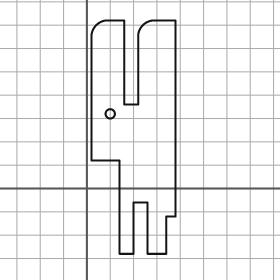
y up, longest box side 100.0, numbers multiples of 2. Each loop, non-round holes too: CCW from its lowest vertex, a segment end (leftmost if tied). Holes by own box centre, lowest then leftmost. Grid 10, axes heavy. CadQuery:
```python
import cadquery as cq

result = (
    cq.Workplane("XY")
    .moveTo(14.0, -28.0)
    .lineTo(20.0, -28.0)
    .lineTo(20.0, -6.0)
    .lineTo(26.0, -6.0)
    .lineTo(26.0, -28.0)
    .lineTo(34.0, -28.0)
    .lineTo(34.0, -12.0)
    .lineTo(38.0, -12.0)
    .lineTo(38.0, 72.0)
    .lineTo(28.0, 72.0)
    .threePointArc((24.0, 70.0), (22.0, 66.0))
    .lineTo(22.0, 36.0)
    .lineTo(16.0, 36.0)
    .lineTo(16.0, 72.0)
    .lineTo(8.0, 72.0)
    .threePointArc((4.0, 70.0), (2.0, 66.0))
    .lineTo(2.0, 12.0)
    .lineTo(14.0, 12.0)
    .close()
    .moveTo(10.0, 32.0)
    .circle(2.0)
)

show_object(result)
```